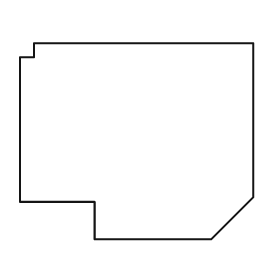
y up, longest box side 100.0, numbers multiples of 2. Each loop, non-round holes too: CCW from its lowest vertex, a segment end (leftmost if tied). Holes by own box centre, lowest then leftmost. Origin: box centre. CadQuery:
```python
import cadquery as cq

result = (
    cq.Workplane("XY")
    .moveTo(-18.0, -42.0)
    .lineTo(32.0, -42.0)
    .lineTo(50.0, -24.0)
    .lineTo(50.0, 42.0)
    .lineTo(-44.0, 42.0)
    .lineTo(-44.0, 36.0)
    .lineTo(-50.0, 36.0)
    .lineTo(-50.0, -26.0)
    .lineTo(-18.0, -26.0)
    .close()
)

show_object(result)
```